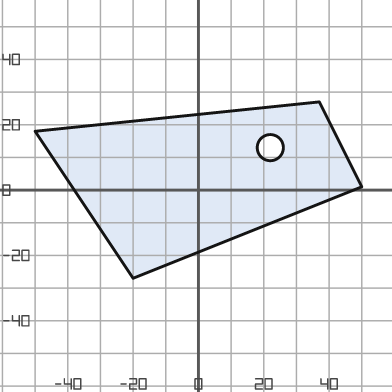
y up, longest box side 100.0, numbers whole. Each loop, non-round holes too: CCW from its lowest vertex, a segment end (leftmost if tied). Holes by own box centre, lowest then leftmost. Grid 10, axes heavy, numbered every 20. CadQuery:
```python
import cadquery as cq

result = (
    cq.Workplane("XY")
    .moveTo(-20.0, -27.0)
    .lineTo(50.0, 1.0)
    .lineTo(37.0, 27.0)
    .lineTo(-50.0, 18.0)
    .close()
    .moveTo(22.0, 13.0)
    .circle(4.0)
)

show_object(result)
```